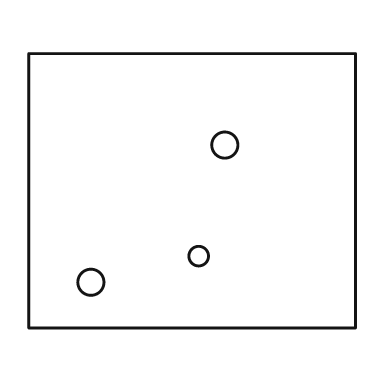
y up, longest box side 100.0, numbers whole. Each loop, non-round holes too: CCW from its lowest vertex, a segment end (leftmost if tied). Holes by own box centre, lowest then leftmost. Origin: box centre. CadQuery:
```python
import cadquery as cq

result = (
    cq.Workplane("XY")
    .moveTo(-50.0, -42.0)
    .lineTo(50.0, -42.0)
    .lineTo(50.0, 42.0)
    .lineTo(-50.0, 42.0)
    .close()
    .moveTo(-31.0, -28.0)
    .circle(4.0)
    .moveTo(2.0, -20.0)
    .circle(3.0)
    .moveTo(10.0, 14.0)
    .circle(4.0)
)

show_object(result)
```